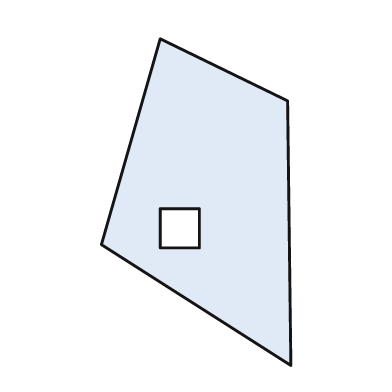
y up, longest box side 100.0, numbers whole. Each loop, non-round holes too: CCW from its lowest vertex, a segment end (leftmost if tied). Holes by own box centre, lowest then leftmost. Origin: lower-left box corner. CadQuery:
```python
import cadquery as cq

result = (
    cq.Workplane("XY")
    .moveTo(58.0, 0.0)
    .lineTo(57.0, 81.0)
    .lineTo(18.0, 100.0)
    .lineTo(0.0, 37.0)
    .close()
    .moveTo(18.0, 36.0)
    .lineTo(30.0, 36.0)
    .lineTo(30.0, 48.0)
    .lineTo(18.0, 48.0)
    .close()
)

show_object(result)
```